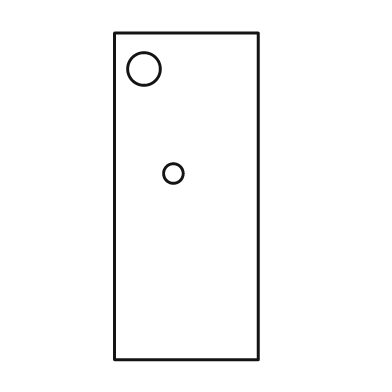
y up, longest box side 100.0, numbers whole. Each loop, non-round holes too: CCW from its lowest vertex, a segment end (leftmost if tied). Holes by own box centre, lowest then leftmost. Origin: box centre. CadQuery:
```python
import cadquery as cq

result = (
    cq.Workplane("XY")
    .moveTo(-22.0, -50.0)
    .lineTo(22.0, -50.0)
    .lineTo(22.0, 50.0)
    .lineTo(-22.0, 50.0)
    .close()
    .moveTo(-4.0, 7.0)
    .circle(3.0)
    .moveTo(-13.0, 39.0)
    .circle(5.0)
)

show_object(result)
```